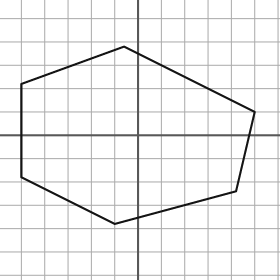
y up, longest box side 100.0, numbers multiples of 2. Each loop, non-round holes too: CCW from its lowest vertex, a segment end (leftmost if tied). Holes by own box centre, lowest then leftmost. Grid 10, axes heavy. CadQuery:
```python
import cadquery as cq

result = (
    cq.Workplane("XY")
    .moveTo(-10.0, -38.0)
    .lineTo(42.0, -24.0)
    .lineTo(50.0, 10.0)
    .lineTo(-6.0, 38.0)
    .lineTo(-50.0, 22.0)
    .lineTo(-50.0, -18.0)
    .close()
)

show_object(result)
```